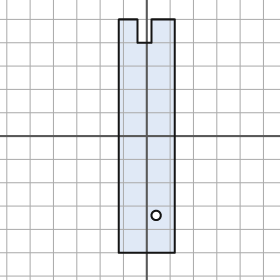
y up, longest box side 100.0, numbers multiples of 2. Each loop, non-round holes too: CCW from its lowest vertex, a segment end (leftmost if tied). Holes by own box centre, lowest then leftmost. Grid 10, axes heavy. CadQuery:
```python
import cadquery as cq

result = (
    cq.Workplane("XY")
    .moveTo(-12.0, -50.0)
    .lineTo(12.0, -50.0)
    .lineTo(12.0, 50.0)
    .lineTo(2.0, 50.0)
    .lineTo(2.0, 40.0)
    .lineTo(-4.0, 40.0)
    .lineTo(-4.0, 50.0)
    .lineTo(-12.0, 50.0)
    .close()
    .moveTo(4.0, -34.0)
    .circle(2.0)
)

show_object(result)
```